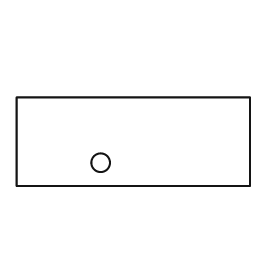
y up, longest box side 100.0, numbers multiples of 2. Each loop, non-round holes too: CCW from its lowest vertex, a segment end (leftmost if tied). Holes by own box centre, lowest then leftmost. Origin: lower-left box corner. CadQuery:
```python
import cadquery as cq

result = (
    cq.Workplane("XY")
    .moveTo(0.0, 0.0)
    .lineTo(100.0, 0.0)
    .lineTo(100.0, 38.0)
    .lineTo(0.0, 38.0)
    .close()
    .moveTo(36.0, 10.0)
    .circle(4.0)
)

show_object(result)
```